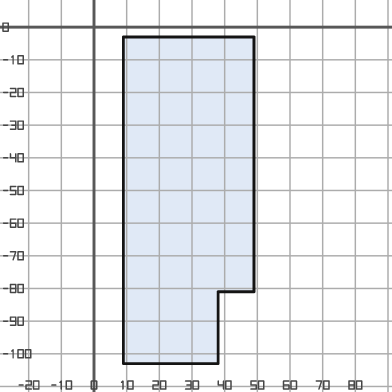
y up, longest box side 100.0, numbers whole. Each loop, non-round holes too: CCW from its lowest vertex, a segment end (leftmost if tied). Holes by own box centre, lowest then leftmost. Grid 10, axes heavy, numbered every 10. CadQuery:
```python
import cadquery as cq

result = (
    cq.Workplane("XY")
    .moveTo(9.0, -103.0)
    .lineTo(38.0, -103.0)
    .lineTo(38.0, -81.0)
    .lineTo(49.0, -81.0)
    .lineTo(49.0, -3.0)
    .lineTo(9.0, -3.0)
    .close()
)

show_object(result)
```